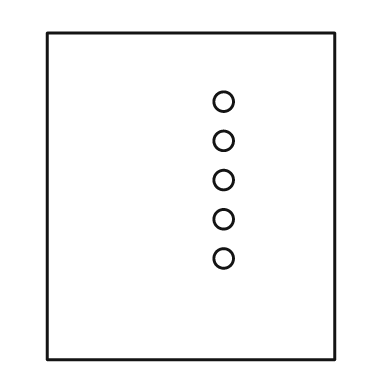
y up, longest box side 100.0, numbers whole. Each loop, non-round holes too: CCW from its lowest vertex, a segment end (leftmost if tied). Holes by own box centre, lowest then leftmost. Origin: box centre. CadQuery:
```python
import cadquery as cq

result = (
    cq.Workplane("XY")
    .moveTo(-44.0, -50.0)
    .lineTo(44.0, -50.0)
    .lineTo(44.0, 50.0)
    .lineTo(-44.0, 50.0)
    .close()
    .moveTo(10.0, -19.0)
    .circle(3.0)
    .moveTo(10.0, -7.0)
    .circle(3.0)
    .moveTo(10.0, 5.0)
    .circle(3.0)
    .moveTo(10.0, 17.0)
    .circle(3.0)
    .moveTo(10.0, 29.0)
    .circle(3.0)
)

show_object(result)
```